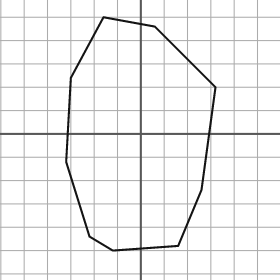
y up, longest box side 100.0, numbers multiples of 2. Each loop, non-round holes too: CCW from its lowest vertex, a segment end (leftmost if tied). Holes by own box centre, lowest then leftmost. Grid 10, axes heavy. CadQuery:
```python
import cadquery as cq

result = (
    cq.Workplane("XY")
    .moveTo(-12.0, -50.0)
    .lineTo(16.0, -48.0)
    .lineTo(26.0, -24.0)
    .lineTo(32.0, 20.0)
    .lineTo(6.0, 46.0)
    .lineTo(-16.0, 50.0)
    .lineTo(-30.0, 24.0)
    .lineTo(-32.0, -12.0)
    .lineTo(-22.0, -44.0)
    .close()
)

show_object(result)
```